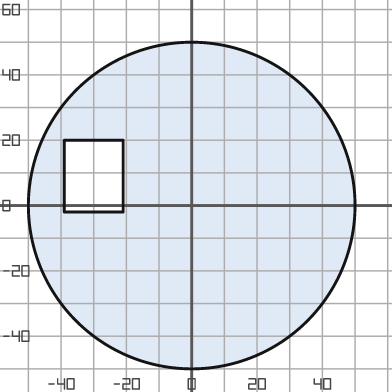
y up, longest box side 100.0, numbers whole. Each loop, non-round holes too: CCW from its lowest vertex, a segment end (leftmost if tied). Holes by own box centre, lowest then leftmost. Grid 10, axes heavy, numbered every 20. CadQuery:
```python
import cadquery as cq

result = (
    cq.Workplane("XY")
    .moveTo(0.0, 0.0)
    .circle(50.0)
    .moveTo(-39.0, -2.0)
    .lineTo(-21.0, -2.0)
    .lineTo(-21.0, 20.0)
    .lineTo(-39.0, 20.0)
    .close()
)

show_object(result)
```